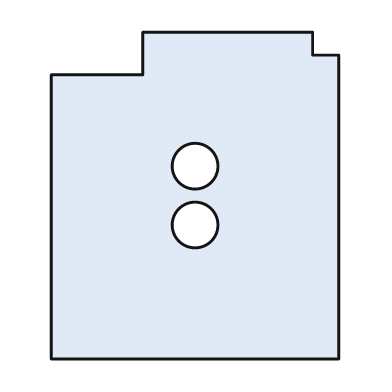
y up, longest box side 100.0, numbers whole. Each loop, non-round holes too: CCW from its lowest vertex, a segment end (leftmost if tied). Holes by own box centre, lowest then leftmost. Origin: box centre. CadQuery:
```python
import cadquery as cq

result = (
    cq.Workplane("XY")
    .moveTo(-44.0, -50.0)
    .lineTo(44.0, -50.0)
    .lineTo(44.0, 43.0)
    .lineTo(36.0, 43.0)
    .lineTo(36.0, 50.0)
    .lineTo(-16.0, 50.0)
    .lineTo(-16.0, 37.0)
    .lineTo(-44.0, 37.0)
    .close()
    .moveTo(0.0, -9.0)
    .circle(7.0)
    .moveTo(0.0, 9.0)
    .circle(7.0)
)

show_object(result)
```